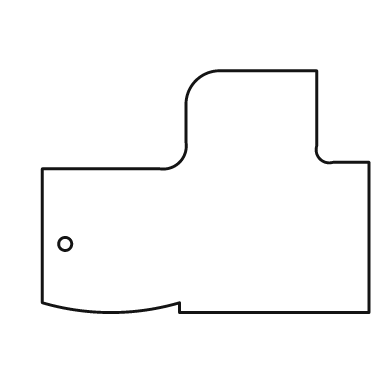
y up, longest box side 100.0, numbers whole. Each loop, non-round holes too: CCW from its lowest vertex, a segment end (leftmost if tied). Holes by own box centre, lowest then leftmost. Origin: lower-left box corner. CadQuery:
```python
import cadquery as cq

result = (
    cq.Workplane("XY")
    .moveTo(42.0, 0.0)
    .lineTo(100.0, 0.0)
    .lineTo(100.0, 46.0)
    .lineTo(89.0, 46.0)
    .threePointArc((85.0, 47.0), (84.0, 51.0))
    .lineTo(84.0, 74.0)
    .lineTo(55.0, 74.0)
    .threePointArc((47.0, 71.0), (44.0, 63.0))
    .lineTo(44.0, 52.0)
    .threePointArc((42.0, 46.0), (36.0, 44.0))
    .lineTo(0.0, 44.0)
    .lineTo(0.0, 3.0)
    .threePointArc((21.0, 0.0), (42.0, 3.0))
    .close()
    .moveTo(7.0, 21.0)
    .circle(2.0)
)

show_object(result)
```